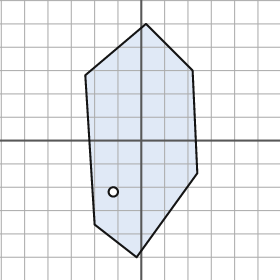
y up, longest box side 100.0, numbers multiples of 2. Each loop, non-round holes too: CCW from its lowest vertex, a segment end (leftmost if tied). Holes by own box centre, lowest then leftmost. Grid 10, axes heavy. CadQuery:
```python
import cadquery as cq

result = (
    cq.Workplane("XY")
    .moveTo(-2.0, -50.0)
    .lineTo(24.0, -14.0)
    .lineTo(22.0, 30.0)
    .lineTo(2.0, 50.0)
    .lineTo(-24.0, 28.0)
    .lineTo(-20.0, -36.0)
    .close()
    .moveTo(-12.0, -22.0)
    .circle(2.0)
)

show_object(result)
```